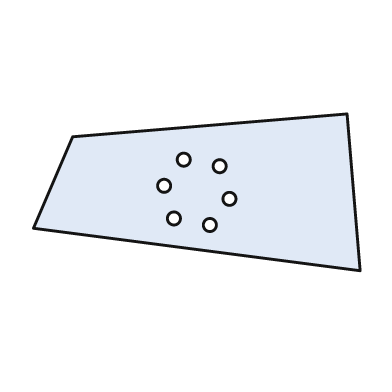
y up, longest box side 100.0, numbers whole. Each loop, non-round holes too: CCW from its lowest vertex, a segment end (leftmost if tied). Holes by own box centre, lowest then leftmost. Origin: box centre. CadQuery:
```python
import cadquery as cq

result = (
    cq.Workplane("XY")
    .moveTo(50.0, -24.0)
    .lineTo(46.0, 24.0)
    .lineTo(-38.0, 17.0)
    .lineTo(-50.0, -11.0)
    .close()
    .moveTo(4.0, -10.0)
    .circle(2.0)
    .moveTo(-7.0, -8.0)
    .circle(2.0)
    .moveTo(10.0, -2.0)
    .circle(2.0)
    .moveTo(-10.0, 2.0)
    .circle(2.0)
    .moveTo(7.0, 8.0)
    .circle(2.0)
    .moveTo(-4.0, 10.0)
    .circle(2.0)
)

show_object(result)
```